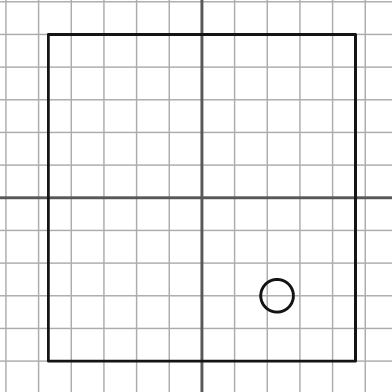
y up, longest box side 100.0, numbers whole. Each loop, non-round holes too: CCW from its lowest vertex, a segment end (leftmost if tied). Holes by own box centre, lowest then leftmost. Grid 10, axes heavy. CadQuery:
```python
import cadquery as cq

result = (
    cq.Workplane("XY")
    .moveTo(-47.0, -50.0)
    .lineTo(47.0, -50.0)
    .lineTo(47.0, 50.0)
    .lineTo(-47.0, 50.0)
    .close()
    .moveTo(23.0, -30.0)
    .circle(5.0)
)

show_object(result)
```